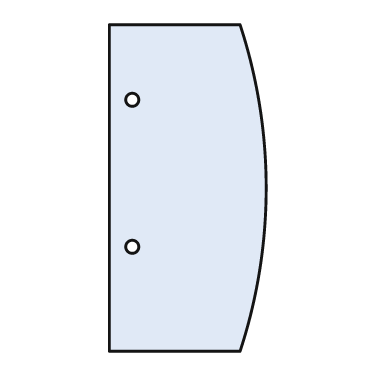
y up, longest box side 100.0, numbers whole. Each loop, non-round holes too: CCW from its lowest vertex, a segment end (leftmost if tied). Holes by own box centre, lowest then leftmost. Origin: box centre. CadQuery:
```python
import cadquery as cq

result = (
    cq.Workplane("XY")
    .moveTo(-24.0, -50.0)
    .lineTo(16.0, -50.0)
    .threePointArc((24.0, 0.0), (16.0, 50.0))
    .lineTo(-24.0, 50.0)
    .close()
    .moveTo(-17.0, -18.0)
    .circle(2.0)
    .moveTo(-17.0, 27.0)
    .circle(2.0)
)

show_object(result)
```